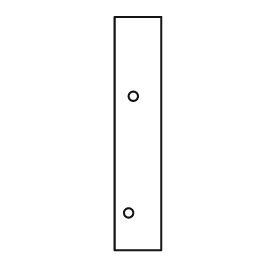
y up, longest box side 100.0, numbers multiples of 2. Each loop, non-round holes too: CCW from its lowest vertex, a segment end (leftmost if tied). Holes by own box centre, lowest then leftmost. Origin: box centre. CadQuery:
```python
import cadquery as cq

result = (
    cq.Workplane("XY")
    .moveTo(-10.0, -50.0)
    .lineTo(10.0, -50.0)
    .lineTo(10.0, 50.0)
    .lineTo(-10.0, 50.0)
    .close()
    .moveTo(-4.0, -34.0)
    .circle(2.0)
    .moveTo(-2.0, 16.0)
    .circle(2.0)
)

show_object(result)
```